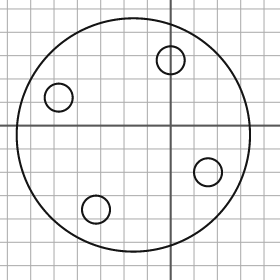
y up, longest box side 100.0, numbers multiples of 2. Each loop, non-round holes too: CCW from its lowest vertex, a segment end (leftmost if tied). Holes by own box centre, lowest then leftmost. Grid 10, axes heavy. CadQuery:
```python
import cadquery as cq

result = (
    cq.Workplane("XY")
    .moveTo(-16.0, -4.0)
    .circle(50.0)
    .moveTo(-32.0, -36.0)
    .circle(6.0)
    .moveTo(16.0, -20.0)
    .circle(6.0)
    .moveTo(-48.0, 12.0)
    .circle(6.0)
    .moveTo(0.0, 28.0)
    .circle(6.0)
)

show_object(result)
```